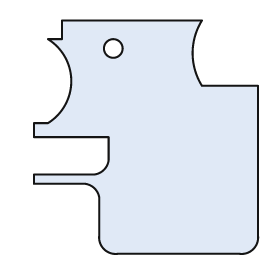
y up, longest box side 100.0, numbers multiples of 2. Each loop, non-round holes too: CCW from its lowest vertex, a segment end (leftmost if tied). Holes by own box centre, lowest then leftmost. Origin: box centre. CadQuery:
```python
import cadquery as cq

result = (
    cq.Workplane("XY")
    .moveTo(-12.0, -50.0)
    .lineTo(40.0, -50.0)
    .threePointArc((46.0, -48.0), (48.0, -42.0))
    .lineTo(48.0, 22.0)
    .lineTo(24.0, 22.0)
    .threePointArc((20.0, 36.0), (24.0, 50.0))
    .lineTo(-36.0, 50.0)
    .lineTo(-36.0, 42.0)
    .lineTo(-42.0, 42.0)
    .threePointArc((-32.0, 24.0), (-42.0, 6.0))
    .lineTo(-48.0, 6.0)
    .lineTo(-48.0, 0.0)
    .lineTo(-16.0, 0.0)
    .lineTo(-16.0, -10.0)
    .threePointArc((-18.0, -14.0), (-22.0, -16.0))
    .lineTo(-48.0, -16.0)
    .lineTo(-48.0, -20.0)
    .lineTo(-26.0, -20.0)
    .threePointArc((-22.0, -22.0), (-20.0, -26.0))
    .lineTo(-20.0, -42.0)
    .threePointArc((-18.0, -48.0), (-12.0, -50.0))
    .close()
    .moveTo(-14.0, 38.0)
    .circle(4.0)
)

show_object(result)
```